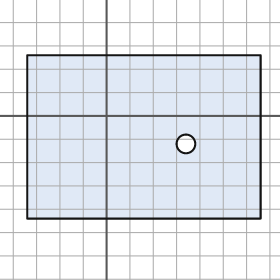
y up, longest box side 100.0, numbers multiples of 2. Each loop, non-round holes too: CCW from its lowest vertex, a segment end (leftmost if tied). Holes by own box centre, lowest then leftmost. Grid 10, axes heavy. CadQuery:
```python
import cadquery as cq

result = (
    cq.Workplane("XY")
    .moveTo(-34.0, -44.0)
    .lineTo(66.0, -44.0)
    .lineTo(66.0, 26.0)
    .lineTo(-34.0, 26.0)
    .close()
    .moveTo(34.0, -12.0)
    .circle(4.0)
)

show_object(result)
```